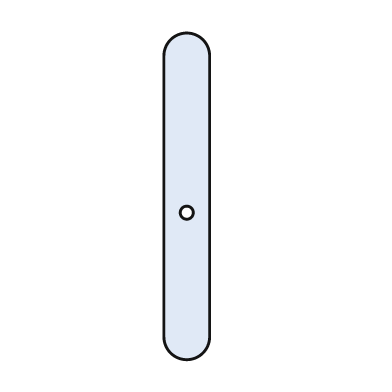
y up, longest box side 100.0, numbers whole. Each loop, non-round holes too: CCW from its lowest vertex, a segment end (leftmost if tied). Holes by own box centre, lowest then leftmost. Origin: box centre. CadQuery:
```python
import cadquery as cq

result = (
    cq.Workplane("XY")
    .moveTo(-7.0, -43.0)
    .threePointArc((0.0, -50.0), (7.0, -43.0))
    .lineTo(7.0, 43.0)
    .threePointArc((0.0, 50.0), (-7.0, 43.0))
    .close()
    .moveTo(0.0, -5.0)
    .circle(2.0)
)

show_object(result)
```